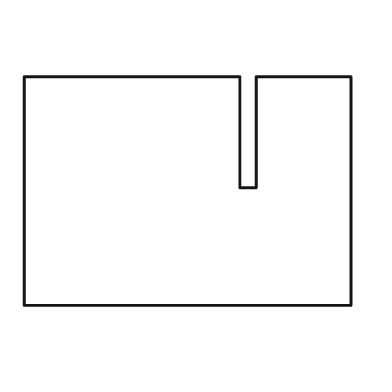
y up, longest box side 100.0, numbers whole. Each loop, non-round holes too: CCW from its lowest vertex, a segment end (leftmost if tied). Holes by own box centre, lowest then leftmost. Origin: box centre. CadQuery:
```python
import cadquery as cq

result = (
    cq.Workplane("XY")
    .moveTo(-50.0, -35.0)
    .lineTo(50.0, -35.0)
    .lineTo(50.0, 35.0)
    .lineTo(21.0, 35.0)
    .lineTo(21.0, 1.0)
    .lineTo(16.0, 1.0)
    .lineTo(16.0, 35.0)
    .lineTo(-50.0, 35.0)
    .close()
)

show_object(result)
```